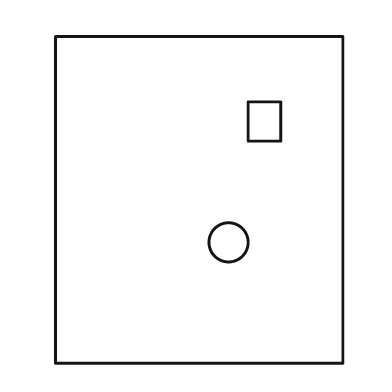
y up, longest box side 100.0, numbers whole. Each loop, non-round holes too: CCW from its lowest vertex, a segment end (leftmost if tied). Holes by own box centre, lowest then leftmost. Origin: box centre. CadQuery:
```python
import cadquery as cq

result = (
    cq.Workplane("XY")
    .moveTo(-44.0, -50.0)
    .lineTo(44.0, -50.0)
    .lineTo(44.0, 50.0)
    .lineTo(-44.0, 50.0)
    .close()
    .moveTo(9.0, -13.0)
    .circle(6.0)
    .moveTo(15.0, 18.0)
    .lineTo(25.0, 18.0)
    .lineTo(25.0, 30.0)
    .lineTo(15.0, 30.0)
    .close()
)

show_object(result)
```